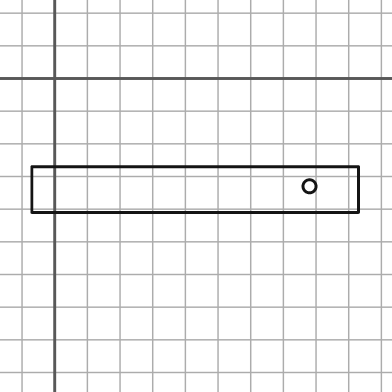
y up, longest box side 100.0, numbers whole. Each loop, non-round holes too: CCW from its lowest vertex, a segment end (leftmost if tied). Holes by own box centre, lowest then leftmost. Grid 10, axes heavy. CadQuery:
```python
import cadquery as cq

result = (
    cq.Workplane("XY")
    .moveTo(-7.0, -41.0)
    .lineTo(93.0, -41.0)
    .lineTo(93.0, -27.0)
    .lineTo(-7.0, -27.0)
    .close()
    .moveTo(78.0, -33.0)
    .circle(2.0)
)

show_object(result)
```